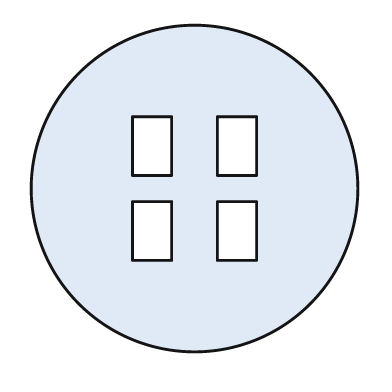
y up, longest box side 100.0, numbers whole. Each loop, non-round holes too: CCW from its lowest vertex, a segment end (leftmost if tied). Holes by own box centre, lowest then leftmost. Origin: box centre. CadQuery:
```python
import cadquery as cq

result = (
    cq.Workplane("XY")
    .moveTo(0.0, 0.0)
    .circle(50.0)
    .moveTo(-19.0, -22.0)
    .lineTo(-7.0, -22.0)
    .lineTo(-7.0, -4.0)
    .lineTo(-19.0, -4.0)
    .close()
    .moveTo(7.0, -22.0)
    .lineTo(19.0, -22.0)
    .lineTo(19.0, -4.0)
    .lineTo(7.0, -4.0)
    .close()
    .moveTo(-19.0, 4.0)
    .lineTo(-7.0, 4.0)
    .lineTo(-7.0, 22.0)
    .lineTo(-19.0, 22.0)
    .close()
    .moveTo(7.0, 4.0)
    .lineTo(19.0, 4.0)
    .lineTo(19.0, 22.0)
    .lineTo(7.0, 22.0)
    .close()
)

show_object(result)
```